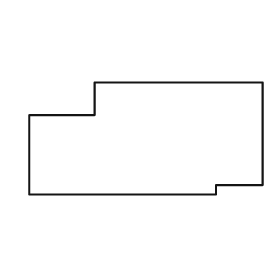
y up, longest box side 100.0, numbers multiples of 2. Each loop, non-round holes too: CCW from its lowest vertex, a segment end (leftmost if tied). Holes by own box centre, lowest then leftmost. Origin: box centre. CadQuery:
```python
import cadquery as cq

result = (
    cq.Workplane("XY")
    .moveTo(-50.0, -24.0)
    .lineTo(30.0, -24.0)
    .lineTo(30.0, -20.0)
    .lineTo(50.0, -20.0)
    .lineTo(50.0, 24.0)
    .lineTo(-22.0, 24.0)
    .lineTo(-22.0, 10.0)
    .lineTo(-50.0, 10.0)
    .close()
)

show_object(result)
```